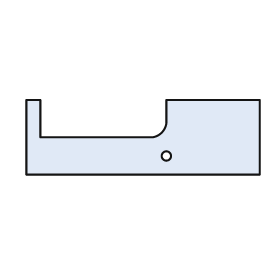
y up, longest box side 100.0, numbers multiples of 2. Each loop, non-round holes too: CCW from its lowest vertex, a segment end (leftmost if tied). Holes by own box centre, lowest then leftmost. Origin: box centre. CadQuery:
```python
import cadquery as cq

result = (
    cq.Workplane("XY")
    .moveTo(-50.0, -16.0)
    .lineTo(50.0, -16.0)
    .lineTo(50.0, 16.0)
    .lineTo(10.0, 16.0)
    .lineTo(10.0, 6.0)
    .threePointArc((8.0, 2.0), (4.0, 0.0))
    .lineTo(-44.0, 0.0)
    .lineTo(-44.0, 16.0)
    .lineTo(-50.0, 16.0)
    .close()
    .moveTo(10.0, -8.0)
    .circle(2.0)
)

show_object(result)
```